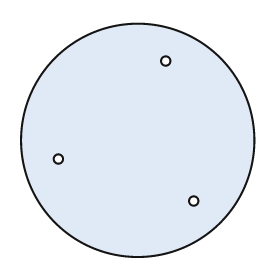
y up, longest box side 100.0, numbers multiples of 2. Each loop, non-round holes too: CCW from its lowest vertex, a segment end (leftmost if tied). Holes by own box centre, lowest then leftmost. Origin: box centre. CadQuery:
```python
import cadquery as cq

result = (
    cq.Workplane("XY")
    .moveTo(0.0, 0.0)
    .circle(50.0)
    .moveTo(24.0, -26.0)
    .circle(2.0)
    .moveTo(-34.0, -8.0)
    .circle(2.0)
    .moveTo(12.0, 34.0)
    .circle(2.0)
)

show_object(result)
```